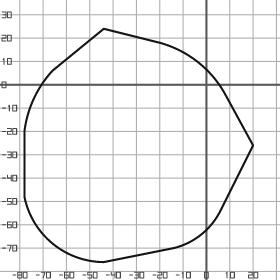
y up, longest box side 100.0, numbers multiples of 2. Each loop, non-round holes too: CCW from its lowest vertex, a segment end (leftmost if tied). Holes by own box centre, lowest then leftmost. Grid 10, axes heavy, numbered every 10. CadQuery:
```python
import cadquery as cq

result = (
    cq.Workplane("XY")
    .moveTo(-44.0, -76.0)
    .lineTo(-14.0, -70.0)
    .threePointArc((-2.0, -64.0), (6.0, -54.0))
    .lineTo(20.0, -26.0)
    .lineTo(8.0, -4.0)
    .threePointArc((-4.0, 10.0), (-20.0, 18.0))
    .lineTo(-44.0, 24.0)
    .lineTo(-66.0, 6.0)
    .threePointArc((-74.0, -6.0), (-78.0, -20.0))
    .lineTo(-78.0, -48.0)
    .threePointArc((-66.0, -68.0), (-44.0, -76.0))
    .close()
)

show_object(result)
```